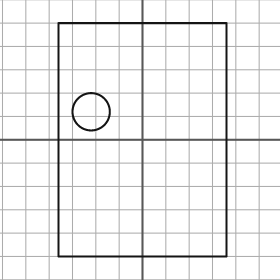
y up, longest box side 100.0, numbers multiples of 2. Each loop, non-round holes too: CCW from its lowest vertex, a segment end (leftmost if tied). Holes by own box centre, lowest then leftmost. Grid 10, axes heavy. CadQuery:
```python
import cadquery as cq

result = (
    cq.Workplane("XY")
    .moveTo(-36.0, -50.0)
    .lineTo(36.0, -50.0)
    .lineTo(36.0, 50.0)
    .lineTo(-36.0, 50.0)
    .close()
    .moveTo(-22.0, 12.0)
    .circle(8.0)
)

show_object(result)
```